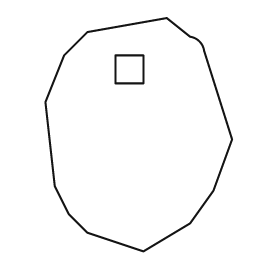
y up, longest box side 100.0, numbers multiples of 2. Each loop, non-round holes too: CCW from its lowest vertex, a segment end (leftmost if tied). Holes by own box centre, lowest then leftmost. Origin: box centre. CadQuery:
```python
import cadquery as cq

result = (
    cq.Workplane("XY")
    .moveTo(2.0, -50.0)
    .lineTo(22.0, -38.0)
    .lineTo(32.0, -24.0)
    .lineTo(40.0, -2.0)
    .lineTo(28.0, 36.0)
    .threePointArc((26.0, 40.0), (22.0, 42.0))
    .lineTo(12.0, 50.0)
    .lineTo(-22.0, 44.0)
    .lineTo(-32.0, 34.0)
    .lineTo(-40.0, 14.0)
    .lineTo(-36.0, -22.0)
    .lineTo(-30.0, -34.0)
    .lineTo(-22.0, -42.0)
    .close()
    .moveTo(-10.0, 22.0)
    .lineTo(2.0, 22.0)
    .lineTo(2.0, 34.0)
    .lineTo(-10.0, 34.0)
    .close()
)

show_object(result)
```